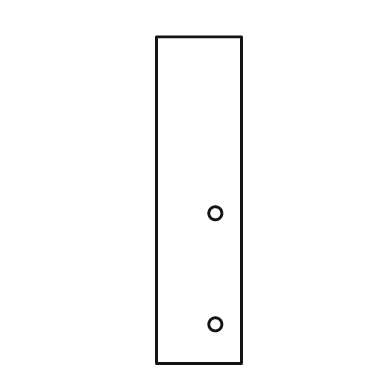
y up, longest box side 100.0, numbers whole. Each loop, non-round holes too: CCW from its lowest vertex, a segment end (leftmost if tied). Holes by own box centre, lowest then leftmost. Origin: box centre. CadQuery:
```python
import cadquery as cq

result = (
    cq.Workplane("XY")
    .moveTo(-13.0, -50.0)
    .lineTo(13.0, -50.0)
    .lineTo(13.0, 50.0)
    .lineTo(-13.0, 50.0)
    .close()
    .moveTo(5.0, -38.0)
    .circle(2.0)
    .moveTo(5.0, -4.0)
    .circle(2.0)
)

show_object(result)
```